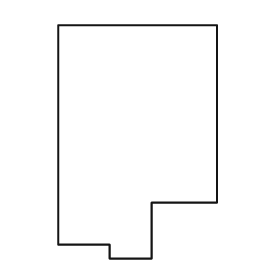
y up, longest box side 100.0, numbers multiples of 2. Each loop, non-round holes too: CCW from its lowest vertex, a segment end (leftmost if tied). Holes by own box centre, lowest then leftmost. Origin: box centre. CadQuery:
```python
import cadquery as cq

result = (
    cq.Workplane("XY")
    .moveTo(-12.0, -50.0)
    .lineTo(6.0, -50.0)
    .lineTo(6.0, -26.0)
    .lineTo(34.0, -26.0)
    .lineTo(34.0, 50.0)
    .lineTo(-34.0, 50.0)
    .lineTo(-34.0, -44.0)
    .lineTo(-12.0, -44.0)
    .close()
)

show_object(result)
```